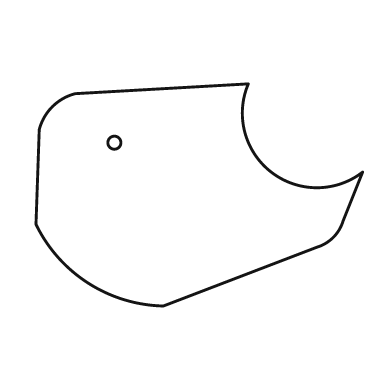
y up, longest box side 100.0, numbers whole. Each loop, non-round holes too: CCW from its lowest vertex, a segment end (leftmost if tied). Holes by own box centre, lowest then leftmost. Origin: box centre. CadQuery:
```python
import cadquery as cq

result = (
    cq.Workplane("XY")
    .moveTo(-11.0, -34.0)
    .lineTo(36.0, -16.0)
    .threePointArc((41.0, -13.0), (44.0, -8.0))
    .lineTo(50.0, 7.0)
    .threePointArc((22.0, 7.0), (15.0, 34.0))
    .lineTo(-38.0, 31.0)
    .threePointArc((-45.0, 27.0), (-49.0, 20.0))
    .lineTo(-50.0, -9.0)
    .threePointArc((-34.0, -27.0), (-11.0, -34.0))
    .close()
    .moveTo(-26.0, 16.0)
    .circle(2.0)
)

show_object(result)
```